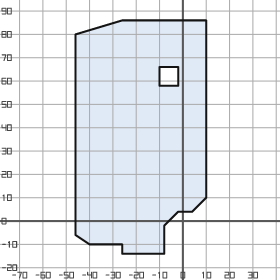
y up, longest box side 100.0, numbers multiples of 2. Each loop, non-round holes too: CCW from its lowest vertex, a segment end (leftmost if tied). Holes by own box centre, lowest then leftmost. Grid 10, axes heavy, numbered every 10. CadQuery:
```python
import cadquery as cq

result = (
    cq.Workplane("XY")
    .moveTo(-26.0, -14.0)
    .lineTo(-8.0, -14.0)
    .lineTo(-8.0, -2.0)
    .lineTo(-2.0, 4.0)
    .lineTo(4.0, 4.0)
    .lineTo(10.0, 10.0)
    .lineTo(10.0, 86.0)
    .lineTo(-26.0, 86.0)
    .lineTo(-46.0, 80.0)
    .lineTo(-46.0, -6.0)
    .lineTo(-40.0, -10.0)
    .lineTo(-26.0, -10.0)
    .close()
    .moveTo(-10.0, 58.0)
    .lineTo(-2.0, 58.0)
    .lineTo(-2.0, 66.0)
    .lineTo(-10.0, 66.0)
    .close()
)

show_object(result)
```